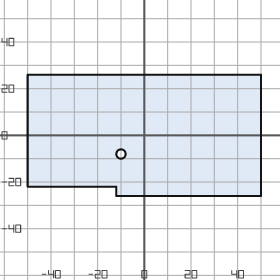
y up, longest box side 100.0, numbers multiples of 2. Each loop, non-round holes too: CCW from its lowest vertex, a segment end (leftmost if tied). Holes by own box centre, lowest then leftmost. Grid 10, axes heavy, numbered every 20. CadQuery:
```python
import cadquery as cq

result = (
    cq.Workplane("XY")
    .moveTo(-12.0, -26.0)
    .lineTo(50.0, -26.0)
    .lineTo(50.0, 26.0)
    .lineTo(-50.0, 26.0)
    .lineTo(-50.0, -22.0)
    .lineTo(-12.0, -22.0)
    .close()
    .moveTo(-10.0, -8.0)
    .circle(2.0)
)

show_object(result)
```